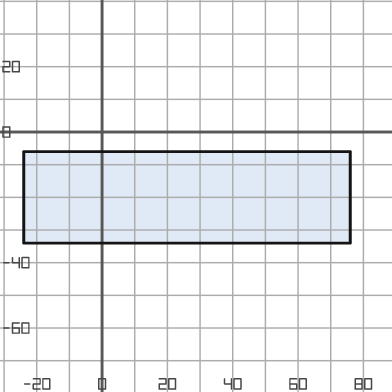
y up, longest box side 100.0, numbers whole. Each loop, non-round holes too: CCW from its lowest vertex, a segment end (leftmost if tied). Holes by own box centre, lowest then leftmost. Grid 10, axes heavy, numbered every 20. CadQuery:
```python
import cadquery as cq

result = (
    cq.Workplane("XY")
    .moveTo(-24.0, -34.0)
    .lineTo(76.0, -34.0)
    .lineTo(76.0, -6.0)
    .lineTo(-24.0, -6.0)
    .close()
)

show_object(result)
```